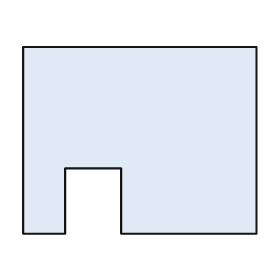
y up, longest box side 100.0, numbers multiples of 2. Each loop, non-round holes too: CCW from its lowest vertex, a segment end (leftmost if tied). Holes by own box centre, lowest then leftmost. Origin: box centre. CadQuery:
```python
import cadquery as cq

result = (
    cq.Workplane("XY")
    .moveTo(-50.0, -40.0)
    .lineTo(-32.0, -40.0)
    .lineTo(-32.0, -12.0)
    .lineTo(-8.0, -12.0)
    .lineTo(-8.0, -40.0)
    .lineTo(50.0, -40.0)
    .lineTo(50.0, 40.0)
    .lineTo(-50.0, 40.0)
    .close()
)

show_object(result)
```